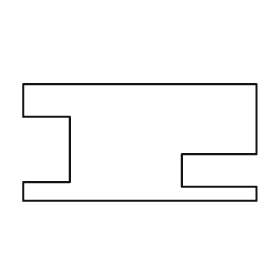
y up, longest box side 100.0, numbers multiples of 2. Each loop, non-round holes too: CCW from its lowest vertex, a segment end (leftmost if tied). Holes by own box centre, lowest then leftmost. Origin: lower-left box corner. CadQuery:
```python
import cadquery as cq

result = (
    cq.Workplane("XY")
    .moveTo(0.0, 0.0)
    .lineTo(100.0, 0.0)
    .lineTo(100.0, 6.0)
    .lineTo(68.0, 6.0)
    .lineTo(68.0, 20.0)
    .lineTo(100.0, 20.0)
    .lineTo(100.0, 50.0)
    .lineTo(0.0, 50.0)
    .lineTo(0.0, 36.0)
    .lineTo(20.0, 36.0)
    .lineTo(20.0, 8.0)
    .lineTo(0.0, 8.0)
    .close()
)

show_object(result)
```